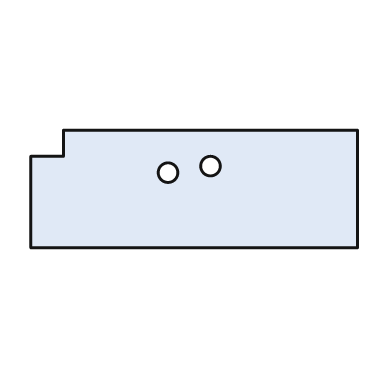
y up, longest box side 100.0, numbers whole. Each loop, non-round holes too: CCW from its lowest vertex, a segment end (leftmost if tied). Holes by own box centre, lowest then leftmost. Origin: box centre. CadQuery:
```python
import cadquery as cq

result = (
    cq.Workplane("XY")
    .moveTo(-50.0, -18.0)
    .lineTo(50.0, -18.0)
    .lineTo(50.0, 18.0)
    .lineTo(-40.0, 18.0)
    .lineTo(-40.0, 10.0)
    .lineTo(-50.0, 10.0)
    .close()
    .moveTo(-8.0, 5.0)
    .circle(3.0)
    .moveTo(5.0, 7.0)
    .circle(3.0)
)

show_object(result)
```